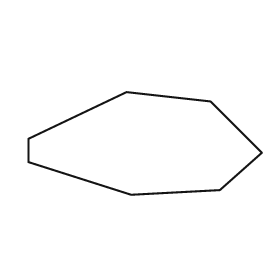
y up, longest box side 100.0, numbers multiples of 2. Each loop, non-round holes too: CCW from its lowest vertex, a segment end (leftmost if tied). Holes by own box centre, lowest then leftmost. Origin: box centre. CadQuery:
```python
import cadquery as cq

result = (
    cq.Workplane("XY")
    .moveTo(-6.0, -22.0)
    .lineTo(32.0, -20.0)
    .lineTo(50.0, -4.0)
    .lineTo(28.0, 18.0)
    .lineTo(-8.0, 22.0)
    .lineTo(-50.0, 2.0)
    .lineTo(-50.0, -8.0)
    .close()
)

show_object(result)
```